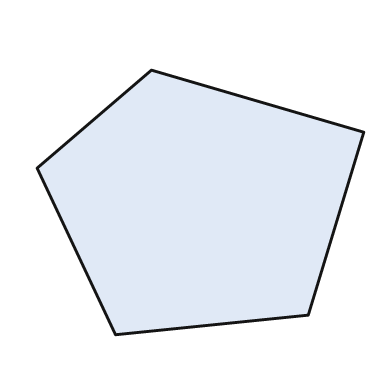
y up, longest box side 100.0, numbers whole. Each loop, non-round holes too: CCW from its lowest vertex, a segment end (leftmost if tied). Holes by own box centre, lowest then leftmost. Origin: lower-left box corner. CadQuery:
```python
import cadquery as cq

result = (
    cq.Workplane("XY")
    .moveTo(24.0, 0.0)
    .lineTo(83.0, 6.0)
    .lineTo(100.0, 62.0)
    .lineTo(35.0, 81.0)
    .lineTo(0.0, 51.0)
    .close()
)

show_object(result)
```